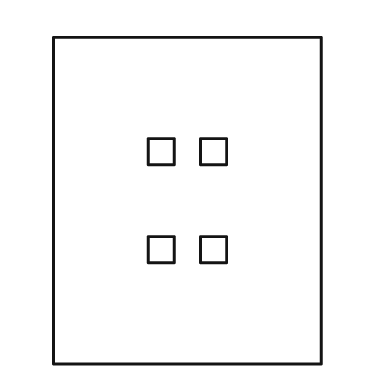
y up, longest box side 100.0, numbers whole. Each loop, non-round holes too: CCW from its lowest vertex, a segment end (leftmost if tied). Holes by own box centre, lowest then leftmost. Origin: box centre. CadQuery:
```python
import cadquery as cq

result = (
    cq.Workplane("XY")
    .moveTo(-41.0, -50.0)
    .lineTo(41.0, -50.0)
    .lineTo(41.0, 50.0)
    .lineTo(-41.0, 50.0)
    .close()
    .moveTo(-12.0, -19.0)
    .lineTo(-4.0, -19.0)
    .lineTo(-4.0, -11.0)
    .lineTo(-12.0, -11.0)
    .close()
    .moveTo(4.0, -19.0)
    .lineTo(12.0, -19.0)
    .lineTo(12.0, -11.0)
    .lineTo(4.0, -11.0)
    .close()
    .moveTo(-12.0, 11.0)
    .lineTo(-4.0, 11.0)
    .lineTo(-4.0, 19.0)
    .lineTo(-12.0, 19.0)
    .close()
    .moveTo(4.0, 11.0)
    .lineTo(12.0, 11.0)
    .lineTo(12.0, 19.0)
    .lineTo(4.0, 19.0)
    .close()
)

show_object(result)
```